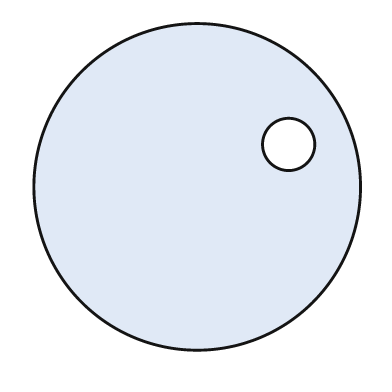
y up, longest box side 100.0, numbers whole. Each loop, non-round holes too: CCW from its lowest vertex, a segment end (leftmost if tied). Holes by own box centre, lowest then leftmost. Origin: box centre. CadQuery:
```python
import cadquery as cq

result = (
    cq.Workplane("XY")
    .moveTo(0.0, 0.0)
    .circle(50.0)
    .moveTo(28.0, 13.0)
    .circle(8.0)
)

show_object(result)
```